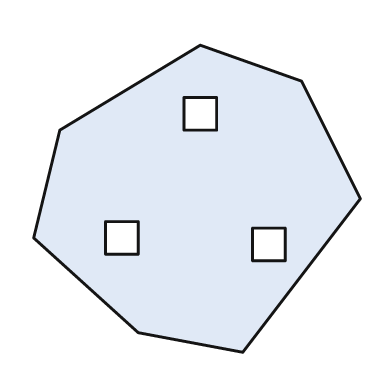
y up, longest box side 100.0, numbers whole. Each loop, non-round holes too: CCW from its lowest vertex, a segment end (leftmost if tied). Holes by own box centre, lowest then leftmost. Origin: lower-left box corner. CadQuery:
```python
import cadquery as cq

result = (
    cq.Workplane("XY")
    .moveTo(64.0, 0.0)
    .lineTo(100.0, 47.0)
    .lineTo(82.0, 83.0)
    .lineTo(51.0, 94.0)
    .lineTo(8.0, 68.0)
    .lineTo(0.0, 35.0)
    .lineTo(32.0, 6.0)
    .close()
    .moveTo(67.0, 28.0)
    .lineTo(77.0, 28.0)
    .lineTo(77.0, 38.0)
    .lineTo(67.0, 38.0)
    .close()
    .moveTo(22.0, 30.0)
    .lineTo(32.0, 30.0)
    .lineTo(32.0, 40.0)
    .lineTo(22.0, 40.0)
    .close()
    .moveTo(46.0, 68.0)
    .lineTo(56.0, 68.0)
    .lineTo(56.0, 78.0)
    .lineTo(46.0, 78.0)
    .close()
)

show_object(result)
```